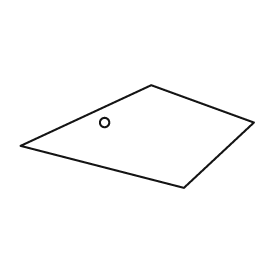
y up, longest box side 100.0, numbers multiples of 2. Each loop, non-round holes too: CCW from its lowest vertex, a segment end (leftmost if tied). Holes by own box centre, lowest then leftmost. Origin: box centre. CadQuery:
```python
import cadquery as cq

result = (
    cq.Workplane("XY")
    .moveTo(20.0, -22.0)
    .lineTo(50.0, 6.0)
    .lineTo(6.0, 22.0)
    .lineTo(-50.0, -4.0)
    .close()
    .moveTo(-14.0, 6.0)
    .circle(2.0)
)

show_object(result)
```